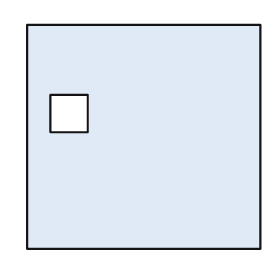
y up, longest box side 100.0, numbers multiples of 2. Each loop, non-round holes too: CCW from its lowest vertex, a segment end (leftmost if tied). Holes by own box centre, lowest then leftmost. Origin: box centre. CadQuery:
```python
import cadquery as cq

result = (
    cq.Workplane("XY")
    .moveTo(-50.0, -48.0)
    .lineTo(50.0, -48.0)
    .lineTo(50.0, 48.0)
    .lineTo(-50.0, 48.0)
    .close()
    .moveTo(-40.0, 2.0)
    .lineTo(-24.0, 2.0)
    .lineTo(-24.0, 18.0)
    .lineTo(-40.0, 18.0)
    .close()
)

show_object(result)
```